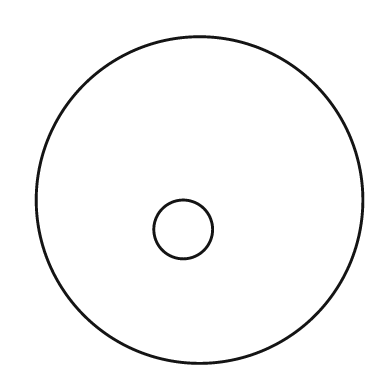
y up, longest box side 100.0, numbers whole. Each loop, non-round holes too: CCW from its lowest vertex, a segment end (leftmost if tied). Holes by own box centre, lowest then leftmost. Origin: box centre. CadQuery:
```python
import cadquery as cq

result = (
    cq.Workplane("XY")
    .moveTo(0.0, 0.0)
    .circle(50.0)
    .moveTo(-5.0, -9.0)
    .circle(9.0)
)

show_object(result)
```